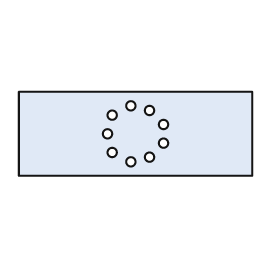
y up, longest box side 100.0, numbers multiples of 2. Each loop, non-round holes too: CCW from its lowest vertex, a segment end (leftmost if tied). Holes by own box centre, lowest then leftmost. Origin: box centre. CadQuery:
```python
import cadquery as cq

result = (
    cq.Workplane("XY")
    .moveTo(-50.0, -18.0)
    .lineTo(50.0, -18.0)
    .lineTo(50.0, 18.0)
    .lineTo(-50.0, 18.0)
    .close()
    .moveTo(-2.0, -12.0)
    .circle(2.0)
    .moveTo(6.0, -10.0)
    .circle(2.0)
    .moveTo(-10.0, -8.0)
    .circle(2.0)
    .moveTo(12.0, -4.0)
    .circle(2.0)
    .moveTo(-12.0, 0.0)
    .circle(2.0)
    .moveTo(12.0, 4.0)
    .circle(2.0)
    .moveTo(-10.0, 8.0)
    .circle(2.0)
    .moveTo(6.0, 10.0)
    .circle(2.0)
    .moveTo(-2.0, 12.0)
    .circle(2.0)
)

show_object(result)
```